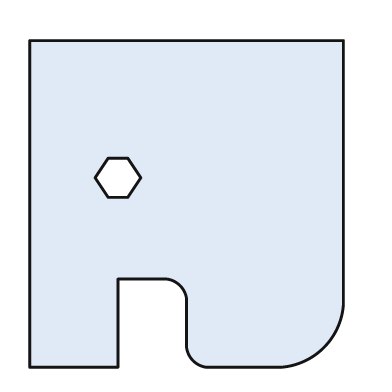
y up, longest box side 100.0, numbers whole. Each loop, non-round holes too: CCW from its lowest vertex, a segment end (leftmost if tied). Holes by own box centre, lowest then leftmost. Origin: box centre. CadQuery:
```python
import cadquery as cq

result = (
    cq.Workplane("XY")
    .moveTo(-48.0, -50.0)
    .lineTo(-21.0, -50.0)
    .lineTo(-21.0, -23.0)
    .lineTo(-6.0, -23.0)
    .threePointArc((-2.0, -25.0), (0.0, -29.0))
    .lineTo(0.0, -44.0)
    .threePointArc((2.0, -48.0), (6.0, -50.0))
    .lineTo(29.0, -50.0)
    .threePointArc((42.0, -44.0), (48.0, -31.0))
    .lineTo(48.0, 50.0)
    .lineTo(-48.0, 50.0)
    .close()
    .moveTo(-24.0, 2.0)
    .lineTo(-18.0, 2.0)
    .lineTo(-14.0, 8.0)
    .lineTo(-18.0, 14.0)
    .lineTo(-24.0, 14.0)
    .lineTo(-28.0, 8.0)
    .close()
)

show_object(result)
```